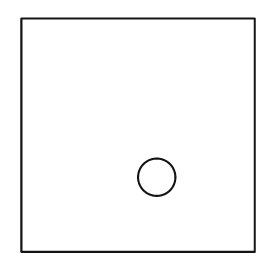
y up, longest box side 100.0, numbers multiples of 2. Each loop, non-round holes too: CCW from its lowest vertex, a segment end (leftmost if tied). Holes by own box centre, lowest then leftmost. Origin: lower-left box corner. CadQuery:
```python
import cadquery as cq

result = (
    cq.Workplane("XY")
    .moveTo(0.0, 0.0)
    .lineTo(100.0, 0.0)
    .lineTo(100.0, 100.0)
    .lineTo(0.0, 100.0)
    .close()
    .moveTo(58.0, 32.0)
    .circle(8.0)
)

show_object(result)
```